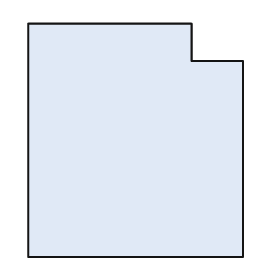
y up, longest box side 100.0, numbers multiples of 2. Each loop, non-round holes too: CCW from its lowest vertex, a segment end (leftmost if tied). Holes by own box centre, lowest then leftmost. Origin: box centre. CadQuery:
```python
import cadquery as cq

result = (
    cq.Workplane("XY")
    .moveTo(-46.0, -50.0)
    .lineTo(46.0, -50.0)
    .lineTo(46.0, 34.0)
    .lineTo(24.0, 34.0)
    .lineTo(24.0, 50.0)
    .lineTo(-46.0, 50.0)
    .close()
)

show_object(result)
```